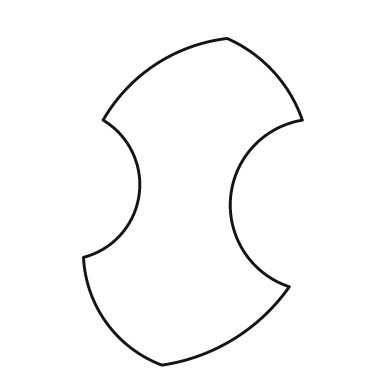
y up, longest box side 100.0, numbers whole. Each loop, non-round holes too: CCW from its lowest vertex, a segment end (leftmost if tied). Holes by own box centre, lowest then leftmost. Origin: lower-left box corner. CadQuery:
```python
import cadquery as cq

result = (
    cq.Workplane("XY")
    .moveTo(24.0, 0.0)
    .threePointArc((46.0, 8.0), (63.0, 24.0))
    .threePointArc((45.0, 51.0), (67.0, 75.0))
    .threePointArc((58.0, 90.0), (44.0, 100.0))
    .threePointArc((22.0, 92.0), (6.0, 75.0))
    .threePointArc((17.0, 52.0), (0.0, 33.0))
    .threePointArc((7.0, 13.0), (24.0, 0.0))
    .close()
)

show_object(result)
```